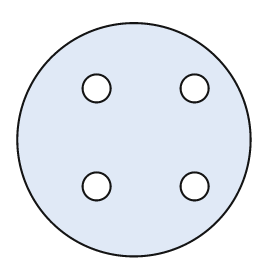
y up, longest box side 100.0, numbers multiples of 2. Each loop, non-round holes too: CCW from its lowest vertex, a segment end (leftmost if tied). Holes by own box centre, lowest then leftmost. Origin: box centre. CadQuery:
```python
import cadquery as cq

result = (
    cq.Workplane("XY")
    .moveTo(0.0, 0.0)
    .circle(50.0)
    .moveTo(-16.0, -20.0)
    .circle(6.0)
    .moveTo(26.0, -20.0)
    .circle(6.0)
    .moveTo(-16.0, 22.0)
    .circle(6.0)
    .moveTo(26.0, 22.0)
    .circle(6.0)
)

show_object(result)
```